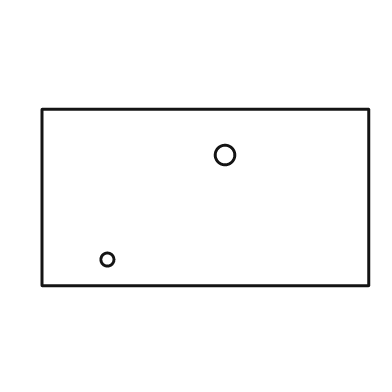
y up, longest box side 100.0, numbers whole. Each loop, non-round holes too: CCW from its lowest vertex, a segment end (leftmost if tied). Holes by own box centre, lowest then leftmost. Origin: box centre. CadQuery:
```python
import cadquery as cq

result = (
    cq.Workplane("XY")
    .moveTo(-50.0, -27.0)
    .lineTo(50.0, -27.0)
    .lineTo(50.0, 27.0)
    .lineTo(-50.0, 27.0)
    .close()
    .moveTo(-30.0, -19.0)
    .circle(2.0)
    .moveTo(6.0, 13.0)
    .circle(3.0)
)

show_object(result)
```